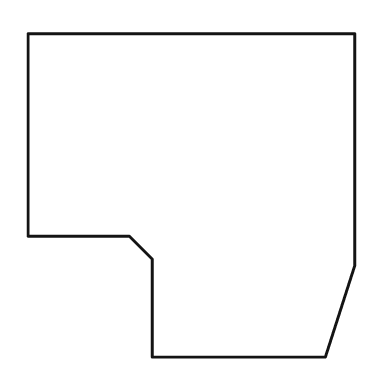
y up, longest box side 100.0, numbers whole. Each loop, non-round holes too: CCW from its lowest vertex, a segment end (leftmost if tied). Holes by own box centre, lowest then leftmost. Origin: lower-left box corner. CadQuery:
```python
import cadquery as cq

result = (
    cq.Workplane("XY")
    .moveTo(38.0, 0.0)
    .lineTo(91.0, 0.0)
    .lineTo(100.0, 28.0)
    .lineTo(100.0, 99.0)
    .lineTo(0.0, 99.0)
    .lineTo(0.0, 37.0)
    .lineTo(31.0, 37.0)
    .lineTo(38.0, 30.0)
    .close()
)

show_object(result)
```